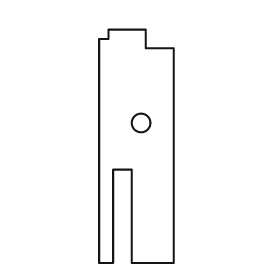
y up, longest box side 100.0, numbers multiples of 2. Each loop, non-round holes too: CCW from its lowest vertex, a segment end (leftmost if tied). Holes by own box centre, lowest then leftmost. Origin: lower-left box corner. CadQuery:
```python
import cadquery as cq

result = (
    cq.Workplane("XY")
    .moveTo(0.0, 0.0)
    .lineTo(6.0, 0.0)
    .lineTo(6.0, 40.0)
    .lineTo(14.0, 40.0)
    .lineTo(14.0, 0.0)
    .lineTo(32.0, 0.0)
    .lineTo(32.0, 92.0)
    .lineTo(20.0, 92.0)
    .lineTo(20.0, 100.0)
    .lineTo(4.0, 100.0)
    .lineTo(4.0, 96.0)
    .lineTo(0.0, 96.0)
    .close()
    .moveTo(18.0, 60.0)
    .circle(4.0)
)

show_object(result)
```